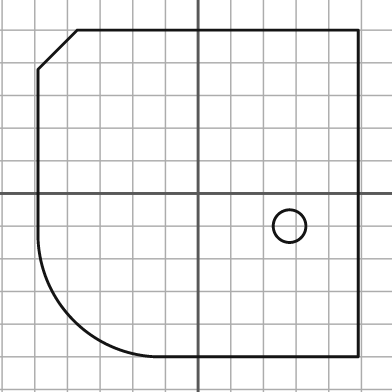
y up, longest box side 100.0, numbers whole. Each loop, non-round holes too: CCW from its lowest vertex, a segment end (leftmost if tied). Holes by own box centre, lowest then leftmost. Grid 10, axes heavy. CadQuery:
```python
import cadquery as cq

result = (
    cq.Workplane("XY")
    .moveTo(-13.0, -50.0)
    .lineTo(49.0, -50.0)
    .lineTo(49.0, 50.0)
    .lineTo(-37.0, 50.0)
    .lineTo(-49.0, 38.0)
    .lineTo(-49.0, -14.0)
    .threePointArc((-38.0, -39.0), (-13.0, -50.0))
    .close()
    .moveTo(28.0, -10.0)
    .circle(5.0)
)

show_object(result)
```